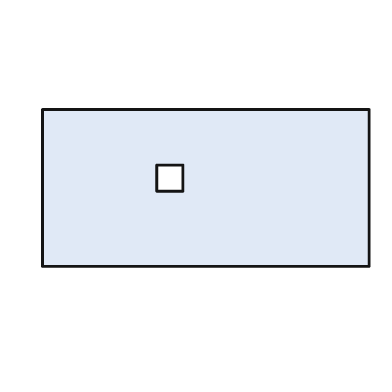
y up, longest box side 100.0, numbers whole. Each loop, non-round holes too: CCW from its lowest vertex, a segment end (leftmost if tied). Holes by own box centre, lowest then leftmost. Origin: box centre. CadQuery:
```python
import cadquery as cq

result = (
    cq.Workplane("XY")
    .moveTo(-50.0, -24.0)
    .lineTo(50.0, -24.0)
    .lineTo(50.0, 24.0)
    .lineTo(-50.0, 24.0)
    .close()
    .moveTo(-15.0, -1.0)
    .lineTo(-7.0, -1.0)
    .lineTo(-7.0, 7.0)
    .lineTo(-15.0, 7.0)
    .close()
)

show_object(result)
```